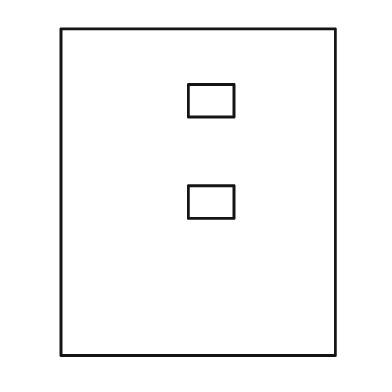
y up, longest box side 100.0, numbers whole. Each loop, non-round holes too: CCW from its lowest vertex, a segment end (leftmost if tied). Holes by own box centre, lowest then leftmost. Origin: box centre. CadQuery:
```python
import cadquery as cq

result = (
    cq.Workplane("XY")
    .moveTo(-42.0, -50.0)
    .lineTo(42.0, -50.0)
    .lineTo(42.0, 50.0)
    .lineTo(-42.0, 50.0)
    .close()
    .moveTo(-3.0, -8.0)
    .lineTo(11.0, -8.0)
    .lineTo(11.0, 2.0)
    .lineTo(-3.0, 2.0)
    .close()
    .moveTo(-3.0, 23.0)
    .lineTo(11.0, 23.0)
    .lineTo(11.0, 33.0)
    .lineTo(-3.0, 33.0)
    .close()
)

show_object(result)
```